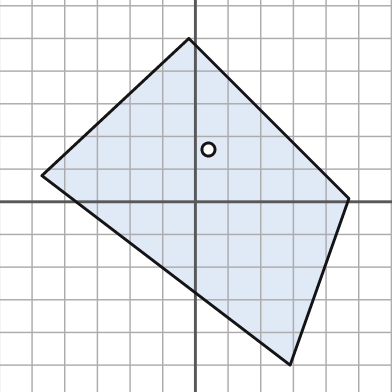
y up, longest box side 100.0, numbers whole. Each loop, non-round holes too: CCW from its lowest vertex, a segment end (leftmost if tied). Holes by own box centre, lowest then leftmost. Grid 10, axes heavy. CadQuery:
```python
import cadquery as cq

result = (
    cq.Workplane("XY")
    .moveTo(29.0, -50.0)
    .lineTo(47.0, 1.0)
    .lineTo(-2.0, 50.0)
    .lineTo(-47.0, 8.0)
    .close()
    .moveTo(4.0, 16.0)
    .circle(2.0)
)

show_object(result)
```